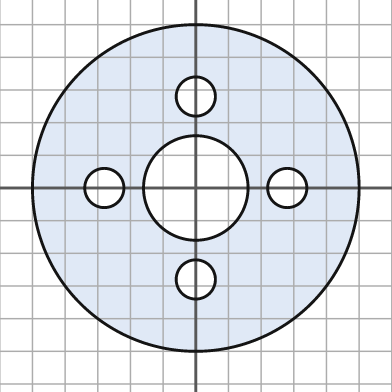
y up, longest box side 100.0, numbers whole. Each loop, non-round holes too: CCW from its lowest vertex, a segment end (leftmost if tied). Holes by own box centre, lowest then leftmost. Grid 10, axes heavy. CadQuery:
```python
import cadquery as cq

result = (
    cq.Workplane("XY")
    .moveTo(0.0, 0.0)
    .circle(50.0)
    .moveTo(0.0, -28.0)
    .circle(6.0)
    .moveTo(-28.0, 0.0)
    .circle(6.0)
    .moveTo(0.0, 0.0)
    .circle(16.0)
    .moveTo(28.0, 0.0)
    .circle(6.0)
    .moveTo(0.0, 28.0)
    .circle(6.0)
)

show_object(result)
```